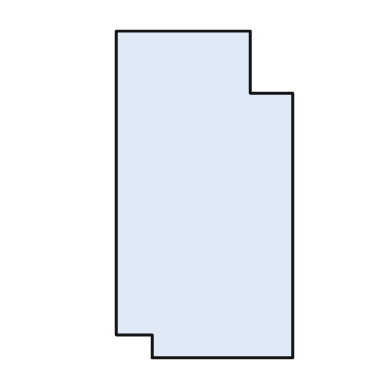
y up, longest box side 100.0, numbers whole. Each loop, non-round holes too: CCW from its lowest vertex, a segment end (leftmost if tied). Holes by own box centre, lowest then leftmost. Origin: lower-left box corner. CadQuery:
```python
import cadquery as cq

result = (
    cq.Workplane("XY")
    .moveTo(11.0, 0.0)
    .lineTo(54.0, 0.0)
    .lineTo(54.0, 81.0)
    .lineTo(41.0, 81.0)
    .lineTo(41.0, 100.0)
    .lineTo(0.0, 100.0)
    .lineTo(0.0, 7.0)
    .lineTo(11.0, 7.0)
    .close()
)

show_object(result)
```